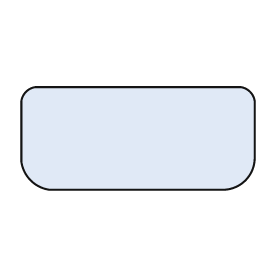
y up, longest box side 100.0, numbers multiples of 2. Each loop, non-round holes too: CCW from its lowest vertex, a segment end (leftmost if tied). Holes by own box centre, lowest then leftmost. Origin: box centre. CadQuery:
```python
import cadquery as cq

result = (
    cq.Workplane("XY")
    .moveTo(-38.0, -22.0)
    .lineTo(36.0, -22.0)
    .threePointArc((46.0, -18.0), (50.0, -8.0))
    .lineTo(50.0, 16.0)
    .threePointArc((48.0, 20.0), (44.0, 22.0))
    .lineTo(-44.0, 22.0)
    .threePointArc((-48.0, 20.0), (-50.0, 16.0))
    .lineTo(-50.0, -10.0)
    .threePointArc((-46.0, -18.0), (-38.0, -22.0))
    .close()
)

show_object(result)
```